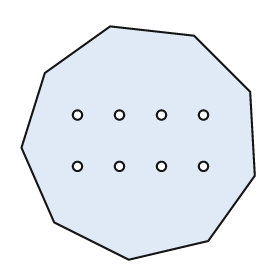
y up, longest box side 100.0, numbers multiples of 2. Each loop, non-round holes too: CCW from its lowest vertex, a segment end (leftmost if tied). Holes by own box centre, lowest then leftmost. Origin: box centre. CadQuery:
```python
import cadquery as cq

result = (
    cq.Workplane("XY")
    .moveTo(-4.0, -50.0)
    .lineTo(30.0, -42.0)
    .lineTo(50.0, -14.0)
    .lineTo(48.0, 22.0)
    .lineTo(24.0, 46.0)
    .lineTo(-12.0, 50.0)
    .lineTo(-40.0, 30.0)
    .lineTo(-50.0, -2.0)
    .lineTo(-36.0, -34.0)
    .close()
    .moveTo(-26.0, -10.0)
    .circle(2.0)
    .moveTo(-8.0, -10.0)
    .circle(2.0)
    .moveTo(10.0, -10.0)
    .circle(2.0)
    .moveTo(28.0, -10.0)
    .circle(2.0)
    .moveTo(-26.0, 12.0)
    .circle(2.0)
    .moveTo(-8.0, 12.0)
    .circle(2.0)
    .moveTo(10.0, 12.0)
    .circle(2.0)
    .moveTo(28.0, 12.0)
    .circle(2.0)
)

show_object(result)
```